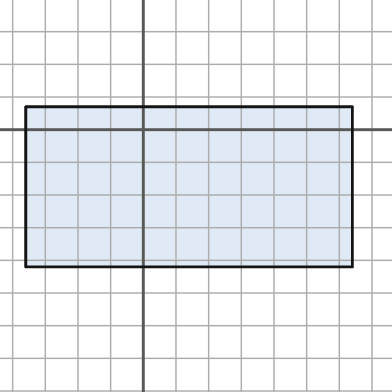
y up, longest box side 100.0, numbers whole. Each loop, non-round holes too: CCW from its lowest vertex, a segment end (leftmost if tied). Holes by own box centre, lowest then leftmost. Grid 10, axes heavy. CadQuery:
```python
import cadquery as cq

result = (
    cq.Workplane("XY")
    .moveTo(-36.0, -42.0)
    .lineTo(64.0, -42.0)
    .lineTo(64.0, 7.0)
    .lineTo(-36.0, 7.0)
    .close()
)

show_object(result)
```